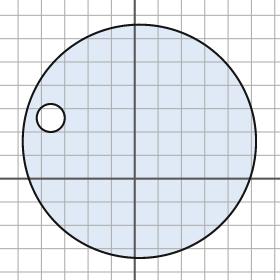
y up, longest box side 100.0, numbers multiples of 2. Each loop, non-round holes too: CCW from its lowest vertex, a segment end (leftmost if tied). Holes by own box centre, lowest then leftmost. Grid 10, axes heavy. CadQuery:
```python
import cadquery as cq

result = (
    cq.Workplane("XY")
    .moveTo(2.0, 16.0)
    .circle(50.0)
    .moveTo(-36.0, 26.0)
    .circle(6.0)
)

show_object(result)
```